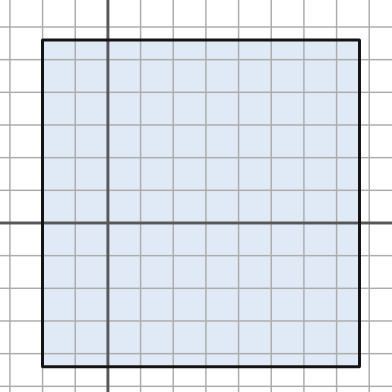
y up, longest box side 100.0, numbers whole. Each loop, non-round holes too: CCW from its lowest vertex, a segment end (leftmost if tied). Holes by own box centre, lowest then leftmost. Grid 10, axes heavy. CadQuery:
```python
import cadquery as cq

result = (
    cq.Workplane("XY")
    .moveTo(-20.0, -44.0)
    .lineTo(77.0, -44.0)
    .lineTo(77.0, 56.0)
    .lineTo(-20.0, 56.0)
    .close()
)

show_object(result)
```